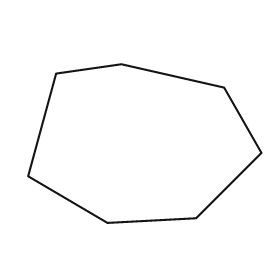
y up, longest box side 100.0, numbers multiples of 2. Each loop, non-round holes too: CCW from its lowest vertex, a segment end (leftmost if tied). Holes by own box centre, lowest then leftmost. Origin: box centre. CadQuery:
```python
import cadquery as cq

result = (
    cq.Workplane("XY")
    .moveTo(-16.0, -34.0)
    .lineTo(22.0, -32.0)
    .lineTo(50.0, -4.0)
    .lineTo(34.0, 24.0)
    .lineTo(-10.0, 34.0)
    .lineTo(-38.0, 30.0)
    .lineTo(-50.0, -14.0)
    .close()
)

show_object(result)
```